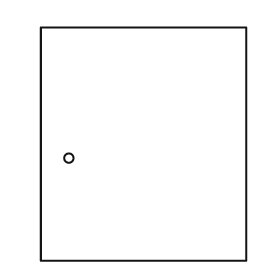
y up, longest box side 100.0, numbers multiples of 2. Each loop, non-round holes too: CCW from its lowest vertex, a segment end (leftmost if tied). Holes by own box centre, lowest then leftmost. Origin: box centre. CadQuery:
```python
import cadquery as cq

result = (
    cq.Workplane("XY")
    .moveTo(-44.0, -50.0)
    .lineTo(44.0, -50.0)
    .lineTo(44.0, 50.0)
    .lineTo(-44.0, 50.0)
    .close()
    .moveTo(-32.0, -6.0)
    .circle(2.0)
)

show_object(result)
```